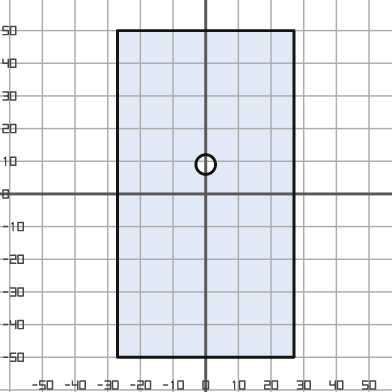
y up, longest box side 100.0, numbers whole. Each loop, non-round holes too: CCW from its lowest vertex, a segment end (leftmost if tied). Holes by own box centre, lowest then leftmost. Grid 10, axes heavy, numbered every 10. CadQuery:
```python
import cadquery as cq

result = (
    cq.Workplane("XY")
    .moveTo(-27.0, -50.0)
    .lineTo(27.0, -50.0)
    .lineTo(27.0, 50.0)
    .lineTo(-27.0, 50.0)
    .close()
    .moveTo(0.0, 9.0)
    .circle(3.0)
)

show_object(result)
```